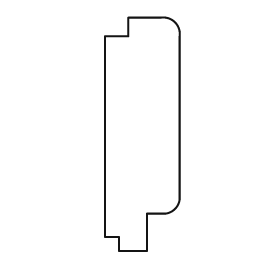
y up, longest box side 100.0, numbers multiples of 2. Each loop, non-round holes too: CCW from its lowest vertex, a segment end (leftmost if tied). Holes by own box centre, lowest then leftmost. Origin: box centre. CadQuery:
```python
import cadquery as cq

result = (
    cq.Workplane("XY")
    .moveTo(-10.0, -50.0)
    .lineTo(2.0, -50.0)
    .lineTo(2.0, -34.0)
    .lineTo(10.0, -34.0)
    .threePointArc((14.0, -32.0), (16.0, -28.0))
    .lineTo(16.0, 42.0)
    .threePointArc((14.0, 48.0), (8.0, 50.0))
    .lineTo(-6.0, 50.0)
    .lineTo(-6.0, 42.0)
    .lineTo(-16.0, 42.0)
    .lineTo(-16.0, -44.0)
    .lineTo(-10.0, -44.0)
    .close()
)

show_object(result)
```